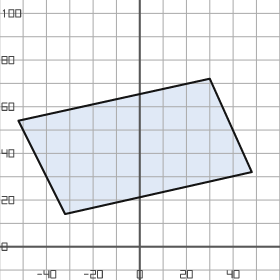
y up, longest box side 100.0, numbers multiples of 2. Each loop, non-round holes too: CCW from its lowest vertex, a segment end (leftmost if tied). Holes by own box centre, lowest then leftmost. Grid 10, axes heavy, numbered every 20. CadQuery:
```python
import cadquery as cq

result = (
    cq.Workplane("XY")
    .moveTo(-32.0, 14.0)
    .lineTo(48.0, 32.0)
    .lineTo(30.0, 72.0)
    .lineTo(-52.0, 54.0)
    .close()
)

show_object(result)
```